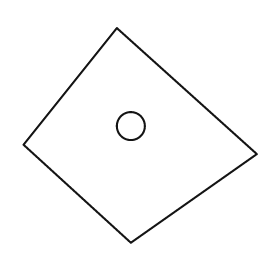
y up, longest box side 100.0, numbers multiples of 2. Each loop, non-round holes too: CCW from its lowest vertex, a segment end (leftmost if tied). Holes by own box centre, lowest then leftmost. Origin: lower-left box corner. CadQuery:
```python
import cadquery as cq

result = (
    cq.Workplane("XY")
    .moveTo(46.0, 0.0)
    .lineTo(100.0, 38.0)
    .lineTo(40.0, 92.0)
    .lineTo(0.0, 42.0)
    .close()
    .moveTo(46.0, 50.0)
    .circle(6.0)
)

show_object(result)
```